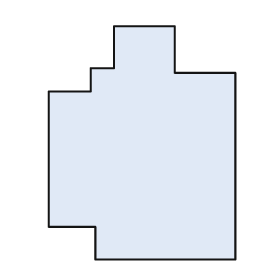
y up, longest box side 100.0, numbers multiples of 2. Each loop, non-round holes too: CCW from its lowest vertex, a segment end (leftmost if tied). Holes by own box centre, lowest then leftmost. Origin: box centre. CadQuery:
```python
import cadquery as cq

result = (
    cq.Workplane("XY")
    .moveTo(-20.0, -50.0)
    .lineTo(40.0, -50.0)
    .lineTo(40.0, 30.0)
    .lineTo(14.0, 30.0)
    .lineTo(14.0, 50.0)
    .lineTo(-12.0, 50.0)
    .lineTo(-12.0, 32.0)
    .lineTo(-22.0, 32.0)
    .lineTo(-22.0, 22.0)
    .lineTo(-40.0, 22.0)
    .lineTo(-40.0, -36.0)
    .lineTo(-20.0, -36.0)
    .close()
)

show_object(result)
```